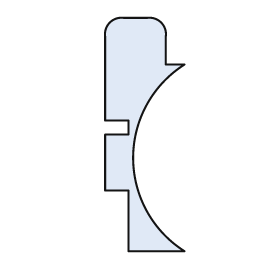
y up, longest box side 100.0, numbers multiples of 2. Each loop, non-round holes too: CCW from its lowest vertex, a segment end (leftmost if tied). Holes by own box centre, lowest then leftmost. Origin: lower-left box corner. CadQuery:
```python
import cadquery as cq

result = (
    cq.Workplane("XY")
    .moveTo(10.0, 0.0)
    .lineTo(34.0, 0.0)
    .threePointArc((12.0, 40.0), (34.0, 80.0))
    .lineTo(26.0, 80.0)
    .lineTo(26.0, 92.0)
    .threePointArc((24.0, 98.0), (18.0, 100.0))
    .lineTo(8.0, 100.0)
    .threePointArc((2.0, 98.0), (0.0, 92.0))
    .lineTo(0.0, 56.0)
    .lineTo(10.0, 56.0)
    .lineTo(10.0, 50.0)
    .lineTo(0.0, 50.0)
    .lineTo(0.0, 26.0)
    .lineTo(10.0, 26.0)
    .close()
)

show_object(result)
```